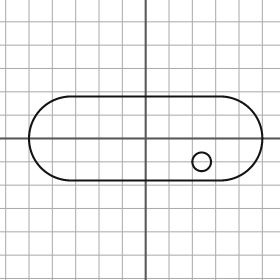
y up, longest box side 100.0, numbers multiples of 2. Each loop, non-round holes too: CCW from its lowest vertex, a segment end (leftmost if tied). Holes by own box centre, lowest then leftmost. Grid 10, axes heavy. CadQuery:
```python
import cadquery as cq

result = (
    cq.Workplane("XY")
    .moveTo(-32.0, -18.0)
    .lineTo(32.0, -18.0)
    .threePointArc((50.0, 0.0), (32.0, 18.0))
    .lineTo(-32.0, 18.0)
    .threePointArc((-50.0, 0.0), (-32.0, -18.0))
    .close()
    .moveTo(24.0, -10.0)
    .circle(4.0)
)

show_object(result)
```